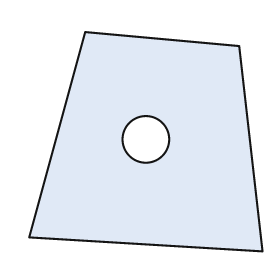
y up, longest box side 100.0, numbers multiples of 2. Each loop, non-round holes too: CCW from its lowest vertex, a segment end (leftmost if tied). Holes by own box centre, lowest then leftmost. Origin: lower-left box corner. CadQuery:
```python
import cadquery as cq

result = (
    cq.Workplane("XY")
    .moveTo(100.0, 0.0)
    .lineTo(90.0, 88.0)
    .lineTo(24.0, 94.0)
    .lineTo(0.0, 6.0)
    .close()
    .moveTo(50.0, 48.0)
    .circle(10.0)
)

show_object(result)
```